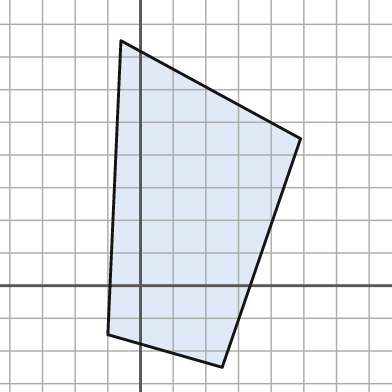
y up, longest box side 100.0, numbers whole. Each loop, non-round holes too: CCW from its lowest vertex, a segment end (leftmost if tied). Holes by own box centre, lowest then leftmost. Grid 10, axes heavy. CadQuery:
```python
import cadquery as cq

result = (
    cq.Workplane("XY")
    .moveTo(25.0, -25.0)
    .lineTo(49.0, 45.0)
    .lineTo(-6.0, 75.0)
    .lineTo(-10.0, -15.0)
    .close()
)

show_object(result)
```